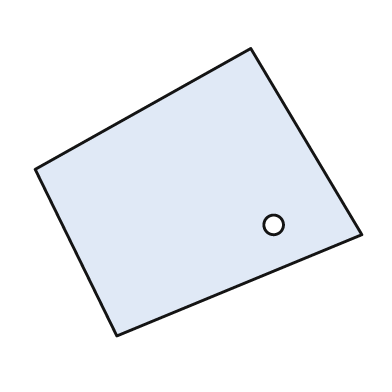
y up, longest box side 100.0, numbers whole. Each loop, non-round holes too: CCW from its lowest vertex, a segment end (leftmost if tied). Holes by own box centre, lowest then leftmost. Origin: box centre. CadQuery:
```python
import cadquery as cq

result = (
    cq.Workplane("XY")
    .moveTo(-25.0, -44.0)
    .lineTo(50.0, -13.0)
    .lineTo(16.0, 44.0)
    .lineTo(-50.0, 7.0)
    .close()
    .moveTo(23.0, -10.0)
    .circle(3.0)
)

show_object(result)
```